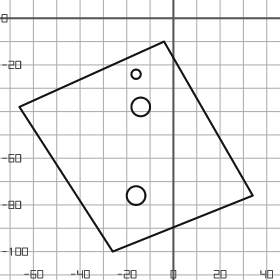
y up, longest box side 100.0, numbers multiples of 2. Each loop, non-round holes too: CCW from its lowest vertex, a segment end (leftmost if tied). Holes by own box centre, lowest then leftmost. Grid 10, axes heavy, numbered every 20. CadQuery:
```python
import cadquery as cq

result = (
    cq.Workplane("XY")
    .moveTo(-26.0, -100.0)
    .lineTo(34.0, -76.0)
    .lineTo(-4.0, -10.0)
    .lineTo(-66.0, -38.0)
    .close()
    .moveTo(-16.0, -76.0)
    .circle(4.0)
    .moveTo(-14.0, -38.0)
    .circle(4.0)
    .moveTo(-16.0, -24.0)
    .circle(2.0)
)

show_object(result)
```